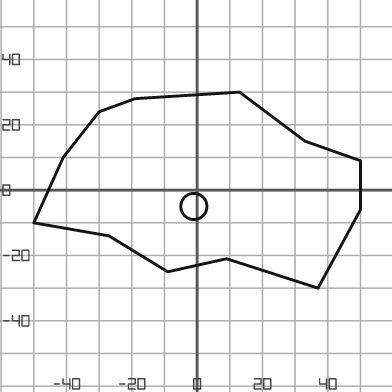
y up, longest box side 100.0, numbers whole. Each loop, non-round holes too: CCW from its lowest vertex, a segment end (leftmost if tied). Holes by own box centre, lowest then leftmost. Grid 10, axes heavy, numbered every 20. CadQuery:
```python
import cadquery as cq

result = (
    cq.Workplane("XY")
    .moveTo(37.0, -30.0)
    .lineTo(50.0, -6.0)
    .lineTo(50.0, 9.0)
    .lineTo(33.0, 15.0)
    .lineTo(13.0, 30.0)
    .lineTo(-19.0, 28.0)
    .lineTo(-30.0, 24.0)
    .lineTo(-41.0, 10.0)
    .lineTo(-50.0, -10.0)
    .lineTo(-27.0, -14.0)
    .lineTo(-9.0, -25.0)
    .lineTo(9.0, -21.0)
    .close()
    .moveTo(-1.0, -5.0)
    .circle(4.0)
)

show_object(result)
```